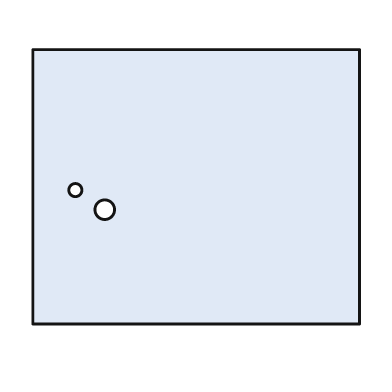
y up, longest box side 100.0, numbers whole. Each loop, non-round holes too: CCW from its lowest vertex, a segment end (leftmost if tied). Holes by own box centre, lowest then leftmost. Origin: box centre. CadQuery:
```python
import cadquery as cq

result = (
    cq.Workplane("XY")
    .moveTo(-50.0, -42.0)
    .lineTo(50.0, -42.0)
    .lineTo(50.0, 42.0)
    .lineTo(-50.0, 42.0)
    .close()
    .moveTo(-28.0, -7.0)
    .circle(3.0)
    .moveTo(-37.0, -1.0)
    .circle(2.0)
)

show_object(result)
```